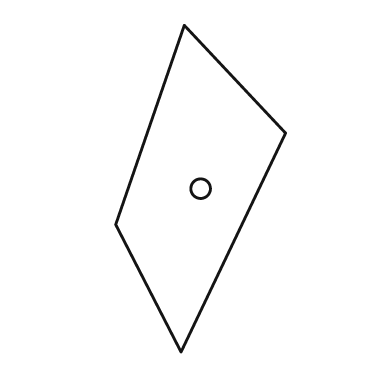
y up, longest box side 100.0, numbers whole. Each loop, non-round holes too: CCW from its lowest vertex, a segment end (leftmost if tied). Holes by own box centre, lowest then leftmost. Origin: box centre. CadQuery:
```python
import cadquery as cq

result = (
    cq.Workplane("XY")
    .moveTo(-6.0, -50.0)
    .lineTo(26.0, 17.0)
    .lineTo(-5.0, 50.0)
    .lineTo(-26.0, -11.0)
    .close()
    .moveTo(0.0, 0.0)
    .circle(3.0)
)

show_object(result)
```